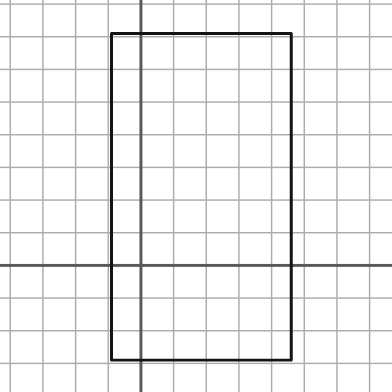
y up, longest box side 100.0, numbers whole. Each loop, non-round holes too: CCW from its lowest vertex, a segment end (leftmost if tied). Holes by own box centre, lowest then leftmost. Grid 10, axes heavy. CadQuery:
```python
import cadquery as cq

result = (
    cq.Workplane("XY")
    .moveTo(-9.0, -29.0)
    .lineTo(46.0, -29.0)
    .lineTo(46.0, 71.0)
    .lineTo(-9.0, 71.0)
    .close()
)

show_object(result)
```